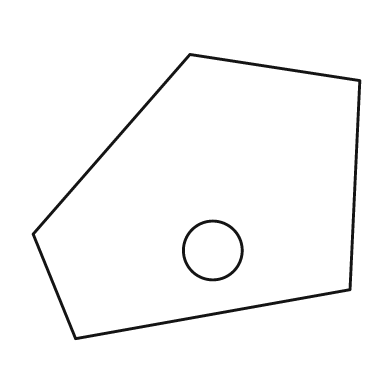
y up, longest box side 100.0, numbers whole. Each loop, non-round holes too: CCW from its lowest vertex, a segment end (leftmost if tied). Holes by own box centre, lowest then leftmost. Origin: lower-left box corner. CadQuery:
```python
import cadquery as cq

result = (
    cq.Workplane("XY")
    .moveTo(13.0, 0.0)
    .lineTo(97.0, 15.0)
    .lineTo(100.0, 79.0)
    .lineTo(48.0, 87.0)
    .lineTo(0.0, 32.0)
    .close()
    .moveTo(55.0, 27.0)
    .circle(9.0)
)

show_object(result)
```